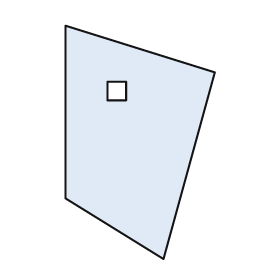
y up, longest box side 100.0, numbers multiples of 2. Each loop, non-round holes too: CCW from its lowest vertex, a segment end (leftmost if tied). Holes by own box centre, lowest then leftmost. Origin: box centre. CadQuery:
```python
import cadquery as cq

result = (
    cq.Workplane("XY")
    .moveTo(10.0, -50.0)
    .lineTo(32.0, 30.0)
    .lineTo(-32.0, 50.0)
    .lineTo(-32.0, -24.0)
    .close()
    .moveTo(-14.0, 18.0)
    .lineTo(-6.0, 18.0)
    .lineTo(-6.0, 26.0)
    .lineTo(-14.0, 26.0)
    .close()
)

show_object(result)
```